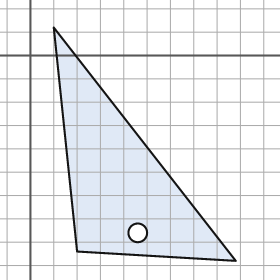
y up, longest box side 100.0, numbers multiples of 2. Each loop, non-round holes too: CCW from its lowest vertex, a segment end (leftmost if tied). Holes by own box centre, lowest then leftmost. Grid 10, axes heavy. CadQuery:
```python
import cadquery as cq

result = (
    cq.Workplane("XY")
    .moveTo(88.0, -88.0)
    .lineTo(10.0, 12.0)
    .lineTo(20.0, -84.0)
    .close()
    .moveTo(46.0, -76.0)
    .circle(4.0)
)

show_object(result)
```